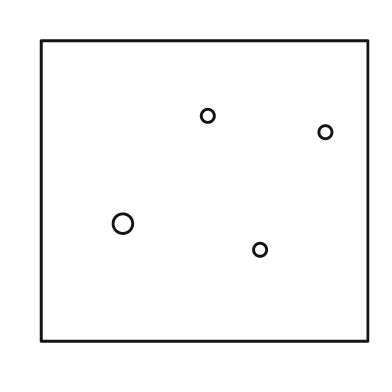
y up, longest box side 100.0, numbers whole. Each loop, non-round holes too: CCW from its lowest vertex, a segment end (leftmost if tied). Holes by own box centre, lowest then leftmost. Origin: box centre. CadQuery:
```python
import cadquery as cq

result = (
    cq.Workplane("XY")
    .moveTo(-50.0, -46.0)
    .lineTo(50.0, -46.0)
    .lineTo(50.0, 46.0)
    .lineTo(-50.0, 46.0)
    .close()
    .moveTo(17.0, -18.0)
    .circle(2.0)
    .moveTo(-25.0, -10.0)
    .circle(3.0)
    .moveTo(37.0, 18.0)
    .circle(2.0)
    .moveTo(1.0, 23.0)
    .circle(2.0)
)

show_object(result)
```